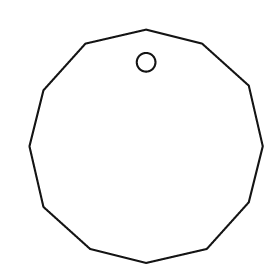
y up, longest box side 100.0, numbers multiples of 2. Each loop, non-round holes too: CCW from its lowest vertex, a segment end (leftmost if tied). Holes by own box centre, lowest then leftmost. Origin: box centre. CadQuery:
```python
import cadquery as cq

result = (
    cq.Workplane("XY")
    .moveTo(0.0, -50.0)
    .lineTo(26.0, -44.0)
    .lineTo(44.0, -24.0)
    .lineTo(50.0, 0.0)
    .lineTo(44.0, 26.0)
    .lineTo(24.0, 44.0)
    .lineTo(0.0, 50.0)
    .lineTo(-26.0, 44.0)
    .lineTo(-44.0, 24.0)
    .lineTo(-50.0, 0.0)
    .lineTo(-44.0, -26.0)
    .lineTo(-24.0, -44.0)
    .close()
    .moveTo(0.0, 36.0)
    .circle(4.0)
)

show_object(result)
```